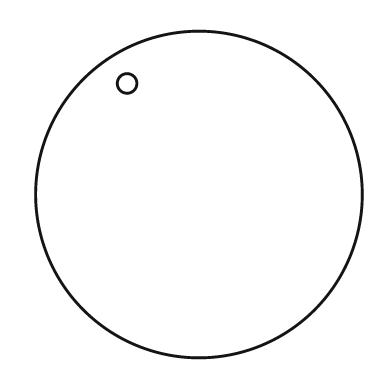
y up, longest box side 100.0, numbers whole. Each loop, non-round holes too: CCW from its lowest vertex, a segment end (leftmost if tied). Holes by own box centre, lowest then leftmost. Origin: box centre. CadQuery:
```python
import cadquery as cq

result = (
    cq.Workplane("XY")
    .moveTo(0.0, 0.0)
    .circle(50.0)
    .moveTo(-22.0, 34.0)
    .circle(3.0)
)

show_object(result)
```